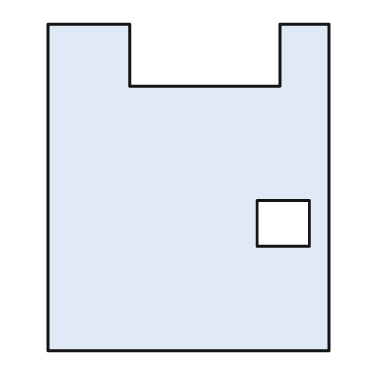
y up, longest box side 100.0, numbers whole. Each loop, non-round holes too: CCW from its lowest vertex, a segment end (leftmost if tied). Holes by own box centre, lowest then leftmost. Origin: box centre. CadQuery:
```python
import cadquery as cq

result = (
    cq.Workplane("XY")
    .moveTo(-43.0, -50.0)
    .lineTo(43.0, -50.0)
    .lineTo(43.0, 50.0)
    .lineTo(28.0, 50.0)
    .lineTo(28.0, 31.0)
    .lineTo(-18.0, 31.0)
    .lineTo(-18.0, 50.0)
    .lineTo(-43.0, 50.0)
    .close()
    .moveTo(21.0, -18.0)
    .lineTo(37.0, -18.0)
    .lineTo(37.0, -4.0)
    .lineTo(21.0, -4.0)
    .close()
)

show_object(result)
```